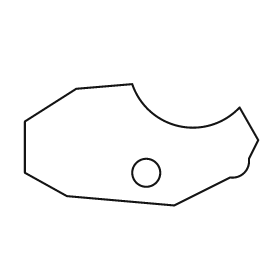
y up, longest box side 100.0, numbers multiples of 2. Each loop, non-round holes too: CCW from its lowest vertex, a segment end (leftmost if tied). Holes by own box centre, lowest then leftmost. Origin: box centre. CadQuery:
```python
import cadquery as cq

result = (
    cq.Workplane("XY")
    .moveTo(14.0, -26.0)
    .lineTo(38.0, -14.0)
    .threePointArc((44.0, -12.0), (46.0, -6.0))
    .lineTo(50.0, 2.0)
    .lineTo(42.0, 16.0)
    .threePointArc((16.0, 8.0), (-4.0, 26.0))
    .lineTo(-28.0, 24.0)
    .lineTo(-50.0, 10.0)
    .lineTo(-50.0, -12.0)
    .lineTo(-32.0, -22.0)
    .close()
    .moveTo(2.0, -12.0)
    .circle(6.0)
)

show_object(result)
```